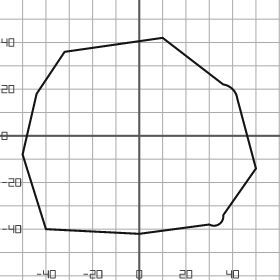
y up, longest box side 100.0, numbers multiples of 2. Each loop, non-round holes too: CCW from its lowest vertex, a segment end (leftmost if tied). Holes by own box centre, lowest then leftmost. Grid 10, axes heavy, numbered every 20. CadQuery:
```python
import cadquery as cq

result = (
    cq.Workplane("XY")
    .moveTo(0.0, -42.0)
    .lineTo(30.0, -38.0)
    .threePointArc((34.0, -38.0), (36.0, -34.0))
    .lineTo(50.0, -14.0)
    .lineTo(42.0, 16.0)
    .threePointArc((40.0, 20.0), (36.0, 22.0))
    .lineTo(10.0, 42.0)
    .lineTo(-32.0, 36.0)
    .lineTo(-44.0, 18.0)
    .lineTo(-50.0, -8.0)
    .lineTo(-40.0, -40.0)
    .close()
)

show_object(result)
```